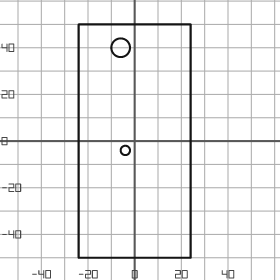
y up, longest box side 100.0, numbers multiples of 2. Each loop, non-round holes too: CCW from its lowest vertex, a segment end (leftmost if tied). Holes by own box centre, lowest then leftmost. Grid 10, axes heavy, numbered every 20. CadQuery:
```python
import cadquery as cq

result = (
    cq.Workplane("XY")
    .moveTo(-24.0, -50.0)
    .lineTo(24.0, -50.0)
    .lineTo(24.0, 50.0)
    .lineTo(-24.0, 50.0)
    .close()
    .moveTo(-4.0, -4.0)
    .circle(2.0)
    .moveTo(-6.0, 40.0)
    .circle(4.0)
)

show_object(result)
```